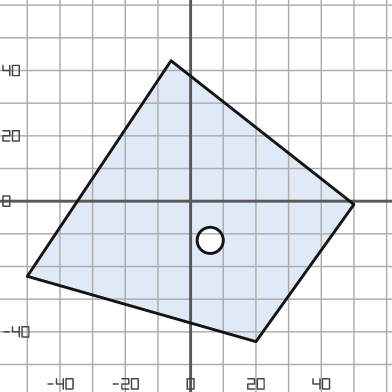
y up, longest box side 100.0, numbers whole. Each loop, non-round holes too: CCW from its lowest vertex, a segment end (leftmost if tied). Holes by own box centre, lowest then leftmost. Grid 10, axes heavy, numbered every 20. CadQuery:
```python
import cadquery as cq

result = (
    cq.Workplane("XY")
    .moveTo(20.0, -43.0)
    .lineTo(50.0, -1.0)
    .lineTo(-6.0, 43.0)
    .lineTo(-50.0, -23.0)
    .close()
    .moveTo(6.0, -12.0)
    .circle(4.0)
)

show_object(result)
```